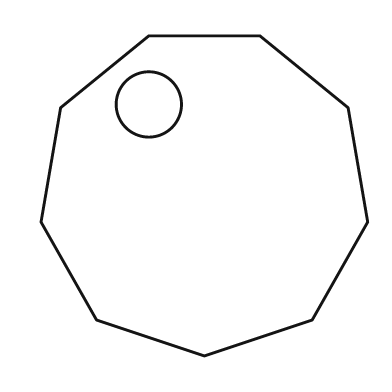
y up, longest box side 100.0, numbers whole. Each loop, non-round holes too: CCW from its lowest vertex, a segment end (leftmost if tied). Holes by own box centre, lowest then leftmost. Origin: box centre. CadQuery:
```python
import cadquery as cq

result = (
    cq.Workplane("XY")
    .moveTo(0.0, -49.0)
    .lineTo(33.0, -38.0)
    .lineTo(50.0, -8.0)
    .lineTo(44.0, 27.0)
    .lineTo(17.0, 49.0)
    .lineTo(-17.0, 49.0)
    .lineTo(-44.0, 27.0)
    .lineTo(-50.0, -8.0)
    .lineTo(-33.0, -38.0)
    .close()
    .moveTo(-17.0, 28.0)
    .circle(10.0)
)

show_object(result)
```